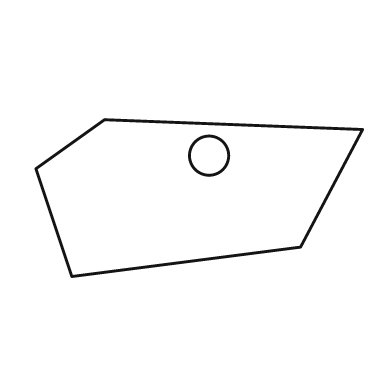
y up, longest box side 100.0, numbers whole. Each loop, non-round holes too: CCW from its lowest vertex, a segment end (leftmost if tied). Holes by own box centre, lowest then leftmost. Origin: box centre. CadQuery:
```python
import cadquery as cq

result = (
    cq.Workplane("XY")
    .moveTo(-39.0, -24.0)
    .lineTo(31.0, -15.0)
    .lineTo(50.0, 21.0)
    .lineTo(-29.0, 24.0)
    .lineTo(-50.0, 9.0)
    .close()
    .moveTo(3.0, 13.0)
    .circle(6.0)
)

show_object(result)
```